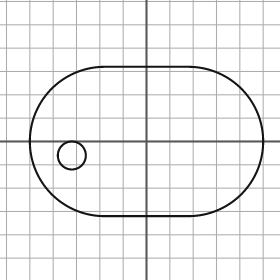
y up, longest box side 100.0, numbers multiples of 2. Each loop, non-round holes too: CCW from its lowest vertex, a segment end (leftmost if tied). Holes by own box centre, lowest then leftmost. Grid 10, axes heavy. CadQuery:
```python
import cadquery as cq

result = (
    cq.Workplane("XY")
    .moveTo(-18.0, -32.0)
    .lineTo(18.0, -32.0)
    .threePointArc((50.0, 0.0), (18.0, 32.0))
    .lineTo(-18.0, 32.0)
    .threePointArc((-50.0, 0.0), (-18.0, -32.0))
    .close()
    .moveTo(-32.0, -6.0)
    .circle(6.0)
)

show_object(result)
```